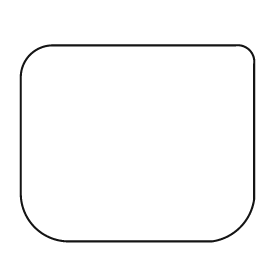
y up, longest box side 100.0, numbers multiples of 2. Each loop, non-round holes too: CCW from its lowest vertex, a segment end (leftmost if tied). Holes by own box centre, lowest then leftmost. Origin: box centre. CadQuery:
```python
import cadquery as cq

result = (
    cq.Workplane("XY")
    .moveTo(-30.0, -42.0)
    .lineTo(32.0, -42.0)
    .threePointArc((44.0, -36.0), (50.0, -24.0))
    .lineTo(50.0, 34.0)
    .threePointArc((48.0, 40.0), (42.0, 42.0))
    .lineTo(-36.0, 42.0)
    .threePointArc((-46.0, 38.0), (-50.0, 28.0))
    .lineTo(-50.0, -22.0)
    .threePointArc((-44.0, -36.0), (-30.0, -42.0))
    .close()
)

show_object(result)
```